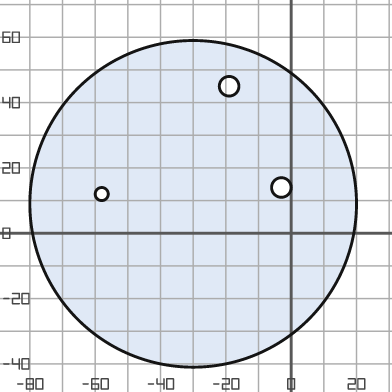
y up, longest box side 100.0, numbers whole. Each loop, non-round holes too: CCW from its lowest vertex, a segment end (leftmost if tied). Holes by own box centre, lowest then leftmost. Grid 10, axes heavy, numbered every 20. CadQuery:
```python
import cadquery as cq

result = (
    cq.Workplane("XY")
    .moveTo(-30.0, 9.0)
    .circle(50.0)
    .moveTo(-58.0, 12.0)
    .circle(2.0)
    .moveTo(-3.0, 14.0)
    .circle(3.0)
    .moveTo(-19.0, 45.0)
    .circle(3.0)
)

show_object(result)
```